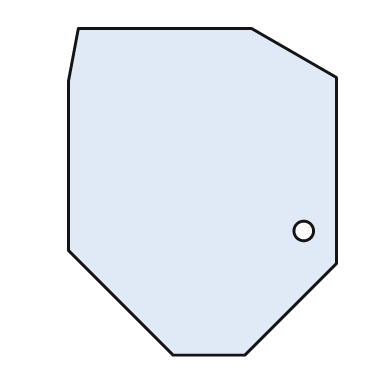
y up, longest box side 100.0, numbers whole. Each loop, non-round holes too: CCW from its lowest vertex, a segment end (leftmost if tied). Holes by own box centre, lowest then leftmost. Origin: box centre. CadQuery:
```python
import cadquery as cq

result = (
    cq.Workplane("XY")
    .moveTo(-9.0, -50.0)
    .lineTo(13.0, -50.0)
    .lineTo(41.0, -22.0)
    .lineTo(41.0, 35.0)
    .lineTo(15.0, 50.0)
    .lineTo(-38.0, 50.0)
    .lineTo(-41.0, 34.0)
    .lineTo(-41.0, -18.0)
    .close()
    .moveTo(31.0, -12.0)
    .circle(3.0)
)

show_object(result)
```